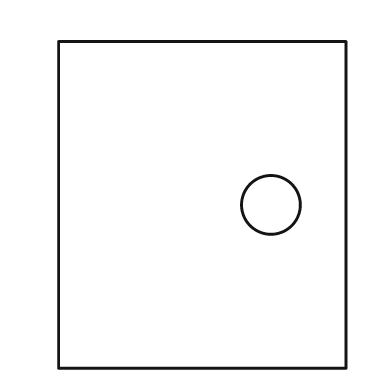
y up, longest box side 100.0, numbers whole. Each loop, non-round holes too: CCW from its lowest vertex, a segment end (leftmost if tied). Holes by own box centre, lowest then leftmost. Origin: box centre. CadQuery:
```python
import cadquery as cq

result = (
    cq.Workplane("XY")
    .moveTo(-44.0, -50.0)
    .lineTo(44.0, -50.0)
    .lineTo(44.0, 50.0)
    .lineTo(-44.0, 50.0)
    .close()
    .moveTo(21.0, 0.0)
    .circle(9.0)
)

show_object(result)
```